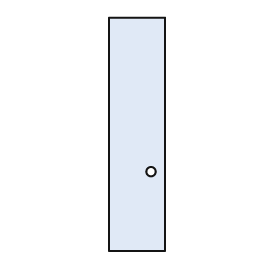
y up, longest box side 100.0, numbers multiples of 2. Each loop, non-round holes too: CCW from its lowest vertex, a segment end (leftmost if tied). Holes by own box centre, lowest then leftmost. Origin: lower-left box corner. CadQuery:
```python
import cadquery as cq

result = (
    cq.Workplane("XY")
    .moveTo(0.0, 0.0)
    .lineTo(24.0, 0.0)
    .lineTo(24.0, 100.0)
    .lineTo(0.0, 100.0)
    .close()
    .moveTo(18.0, 34.0)
    .circle(2.0)
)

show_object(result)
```